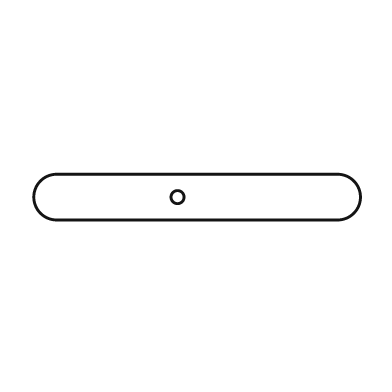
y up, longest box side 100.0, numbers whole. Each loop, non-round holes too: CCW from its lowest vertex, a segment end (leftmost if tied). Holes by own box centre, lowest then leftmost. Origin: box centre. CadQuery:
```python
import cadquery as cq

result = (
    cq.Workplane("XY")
    .moveTo(-43.0, -7.0)
    .lineTo(43.0, -7.0)
    .threePointArc((50.0, 0.0), (43.0, 7.0))
    .lineTo(-43.0, 7.0)
    .threePointArc((-50.0, 0.0), (-43.0, -7.0))
    .close()
    .moveTo(-6.0, 0.0)
    .circle(2.0)
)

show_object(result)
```